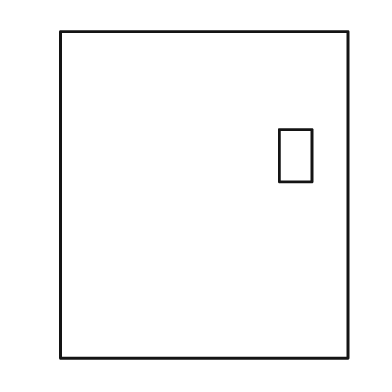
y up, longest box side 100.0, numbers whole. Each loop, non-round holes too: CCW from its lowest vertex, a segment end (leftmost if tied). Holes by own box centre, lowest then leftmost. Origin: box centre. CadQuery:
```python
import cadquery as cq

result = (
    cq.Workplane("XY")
    .moveTo(-44.0, -50.0)
    .lineTo(44.0, -50.0)
    .lineTo(44.0, 50.0)
    .lineTo(-44.0, 50.0)
    .close()
    .moveTo(23.0, 4.0)
    .lineTo(33.0, 4.0)
    .lineTo(33.0, 20.0)
    .lineTo(23.0, 20.0)
    .close()
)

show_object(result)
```